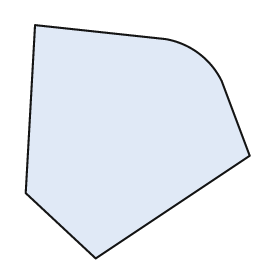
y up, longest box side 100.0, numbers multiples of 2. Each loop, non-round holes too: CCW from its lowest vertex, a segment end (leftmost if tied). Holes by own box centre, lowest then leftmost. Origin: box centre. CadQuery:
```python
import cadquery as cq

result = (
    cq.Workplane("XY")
    .moveTo(-18.0, -50.0)
    .lineTo(48.0, -6.0)
    .lineTo(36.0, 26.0)
    .threePointArc((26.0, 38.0), (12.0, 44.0))
    .lineTo(-44.0, 50.0)
    .lineTo(-48.0, -22.0)
    .close()
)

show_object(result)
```